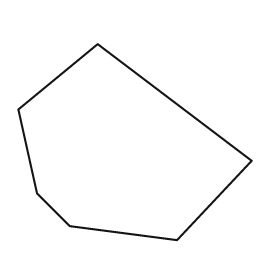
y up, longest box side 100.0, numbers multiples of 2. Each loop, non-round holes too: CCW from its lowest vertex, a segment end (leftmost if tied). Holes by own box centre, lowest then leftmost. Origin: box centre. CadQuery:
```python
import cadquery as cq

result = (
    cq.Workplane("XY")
    .moveTo(18.0, -42.0)
    .lineTo(50.0, -8.0)
    .lineTo(-16.0, 42.0)
    .lineTo(-50.0, 14.0)
    .lineTo(-42.0, -22.0)
    .lineTo(-28.0, -36.0)
    .close()
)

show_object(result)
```